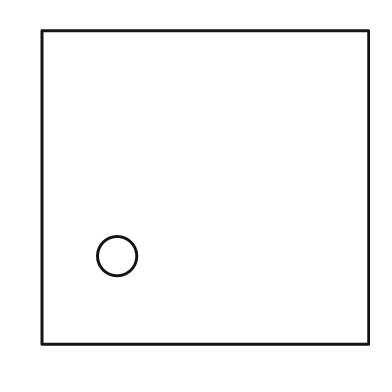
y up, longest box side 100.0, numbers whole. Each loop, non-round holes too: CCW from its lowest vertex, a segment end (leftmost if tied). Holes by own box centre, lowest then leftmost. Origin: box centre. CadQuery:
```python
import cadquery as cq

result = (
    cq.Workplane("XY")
    .moveTo(-50.0, -48.0)
    .lineTo(50.0, -48.0)
    .lineTo(50.0, 48.0)
    .lineTo(-50.0, 48.0)
    .close()
    .moveTo(-27.0, -21.0)
    .circle(6.0)
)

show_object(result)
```